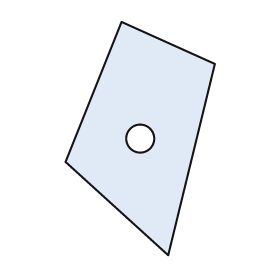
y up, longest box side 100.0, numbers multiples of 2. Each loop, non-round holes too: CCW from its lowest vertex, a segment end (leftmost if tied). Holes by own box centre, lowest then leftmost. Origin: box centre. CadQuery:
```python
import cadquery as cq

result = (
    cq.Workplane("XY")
    .moveTo(12.0, -50.0)
    .lineTo(32.0, 32.0)
    .lineTo(-8.0, 50.0)
    .lineTo(-32.0, -10.0)
    .close()
    .moveTo(0.0, 0.0)
    .circle(6.0)
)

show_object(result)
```